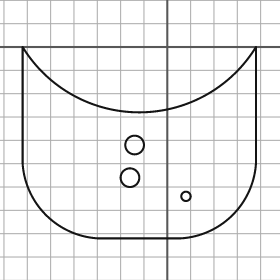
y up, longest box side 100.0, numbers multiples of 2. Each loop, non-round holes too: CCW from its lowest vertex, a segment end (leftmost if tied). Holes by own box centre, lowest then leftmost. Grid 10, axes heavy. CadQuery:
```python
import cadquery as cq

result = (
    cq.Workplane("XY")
    .moveTo(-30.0, -82.0)
    .lineTo(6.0, -82.0)
    .threePointArc((28.0, -72.0), (38.0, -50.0))
    .lineTo(38.0, 0.0)
    .threePointArc((-12.0, -28.0), (-62.0, 0.0))
    .lineTo(-62.0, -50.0)
    .threePointArc((-52.0, -72.0), (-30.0, -82.0))
    .close()
    .moveTo(8.0, -64.0)
    .circle(2.0)
    .moveTo(-16.0, -56.0)
    .circle(4.0)
    .moveTo(-14.0, -42.0)
    .circle(4.0)
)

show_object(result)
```